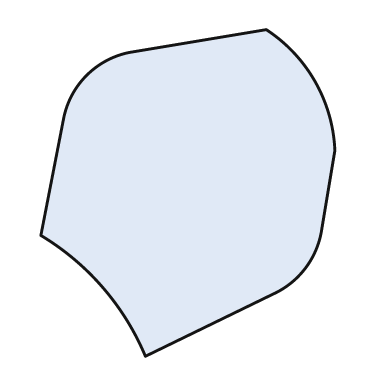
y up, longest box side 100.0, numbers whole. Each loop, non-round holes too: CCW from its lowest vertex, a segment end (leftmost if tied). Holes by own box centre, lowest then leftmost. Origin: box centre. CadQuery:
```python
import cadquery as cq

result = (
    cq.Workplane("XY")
    .moveTo(-13.0, -50.0)
    .lineTo(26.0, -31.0)
    .threePointArc((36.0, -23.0), (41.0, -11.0))
    .lineTo(45.0, 13.0)
    .threePointArc((39.0, 34.0), (24.0, 50.0))
    .lineTo(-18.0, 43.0)
    .threePointArc((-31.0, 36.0), (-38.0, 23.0))
    .lineTo(-45.0, -13.0)
    .threePointArc((-26.0, -29.0), (-13.0, -50.0))
    .close()
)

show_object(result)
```